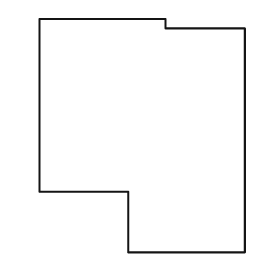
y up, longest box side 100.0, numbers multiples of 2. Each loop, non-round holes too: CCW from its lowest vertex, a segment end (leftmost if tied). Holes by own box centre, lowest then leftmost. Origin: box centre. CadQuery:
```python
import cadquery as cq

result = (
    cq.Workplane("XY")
    .moveTo(-6.0, -50.0)
    .lineTo(44.0, -50.0)
    .lineTo(44.0, 46.0)
    .lineTo(10.0, 46.0)
    .lineTo(10.0, 50.0)
    .lineTo(-44.0, 50.0)
    .lineTo(-44.0, -24.0)
    .lineTo(-6.0, -24.0)
    .close()
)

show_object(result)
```